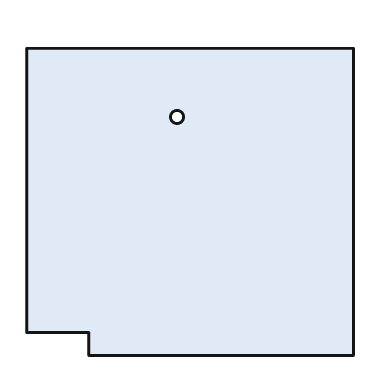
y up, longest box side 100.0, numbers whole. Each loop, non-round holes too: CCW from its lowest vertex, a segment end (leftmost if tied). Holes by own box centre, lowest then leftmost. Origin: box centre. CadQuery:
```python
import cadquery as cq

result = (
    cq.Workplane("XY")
    .moveTo(-31.0, -47.0)
    .lineTo(50.0, -47.0)
    .lineTo(50.0, 47.0)
    .lineTo(-50.0, 47.0)
    .lineTo(-50.0, -40.0)
    .lineTo(-31.0, -40.0)
    .close()
    .moveTo(-4.0, 26.0)
    .circle(2.0)
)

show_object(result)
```